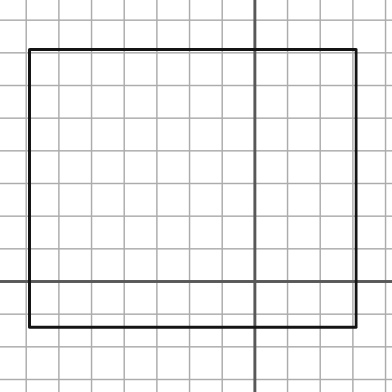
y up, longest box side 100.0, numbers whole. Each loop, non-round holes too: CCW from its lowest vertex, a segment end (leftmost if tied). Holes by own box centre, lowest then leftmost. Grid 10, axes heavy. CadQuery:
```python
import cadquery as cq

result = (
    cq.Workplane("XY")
    .moveTo(-69.0, -14.0)
    .lineTo(31.0, -14.0)
    .lineTo(31.0, 71.0)
    .lineTo(-69.0, 71.0)
    .close()
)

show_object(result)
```